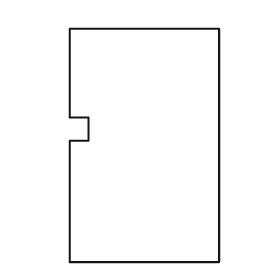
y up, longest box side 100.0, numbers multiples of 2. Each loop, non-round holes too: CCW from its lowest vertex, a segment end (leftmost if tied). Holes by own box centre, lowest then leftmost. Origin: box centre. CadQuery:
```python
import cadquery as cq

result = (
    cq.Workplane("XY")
    .moveTo(-32.0, -50.0)
    .lineTo(32.0, -50.0)
    .lineTo(32.0, 50.0)
    .lineTo(-32.0, 50.0)
    .lineTo(-32.0, 12.0)
    .lineTo(-24.0, 12.0)
    .lineTo(-24.0, 2.0)
    .lineTo(-32.0, 2.0)
    .close()
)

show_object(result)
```